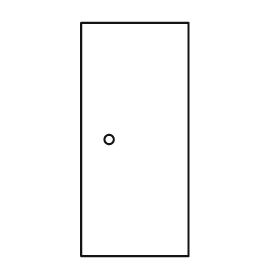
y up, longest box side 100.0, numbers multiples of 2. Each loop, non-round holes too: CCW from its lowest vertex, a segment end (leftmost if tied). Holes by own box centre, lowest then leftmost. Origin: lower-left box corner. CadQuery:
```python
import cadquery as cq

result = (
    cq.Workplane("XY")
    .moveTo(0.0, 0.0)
    .lineTo(46.0, 0.0)
    .lineTo(46.0, 100.0)
    .lineTo(0.0, 100.0)
    .close()
    .moveTo(12.0, 50.0)
    .circle(2.0)
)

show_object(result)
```